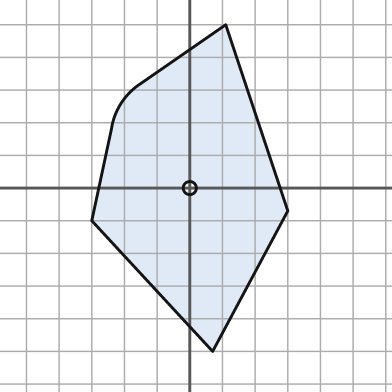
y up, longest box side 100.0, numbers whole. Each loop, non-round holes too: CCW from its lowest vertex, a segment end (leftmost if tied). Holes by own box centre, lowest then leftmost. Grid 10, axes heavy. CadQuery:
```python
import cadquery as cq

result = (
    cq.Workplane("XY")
    .moveTo(7.0, -50.0)
    .lineTo(30.0, -7.0)
    .lineTo(11.0, 50.0)
    .lineTo(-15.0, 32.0)
    .threePointArc((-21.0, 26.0), (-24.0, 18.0))
    .lineTo(-30.0, -10.0)
    .close()
    .moveTo(0.0, 0.0)
    .circle(2.0)
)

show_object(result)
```